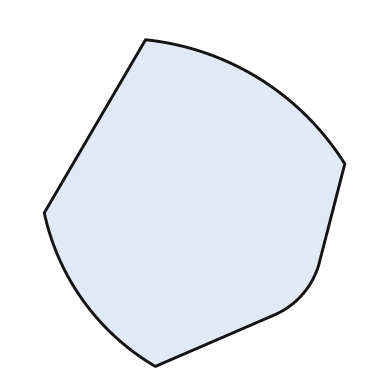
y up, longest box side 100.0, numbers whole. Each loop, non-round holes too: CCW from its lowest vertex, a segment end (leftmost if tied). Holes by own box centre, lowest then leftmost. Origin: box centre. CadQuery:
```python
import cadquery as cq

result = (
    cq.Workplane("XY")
    .moveTo(-12.0, -50.0)
    .lineTo(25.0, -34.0)
    .threePointArc((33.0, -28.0), (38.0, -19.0))
    .lineTo(46.0, 12.0)
    .threePointArc((20.0, 38.0), (-15.0, 50.0))
    .lineTo(-46.0, -3.0)
    .threePointArc((-34.0, -30.0), (-12.0, -50.0))
    .close()
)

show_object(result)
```